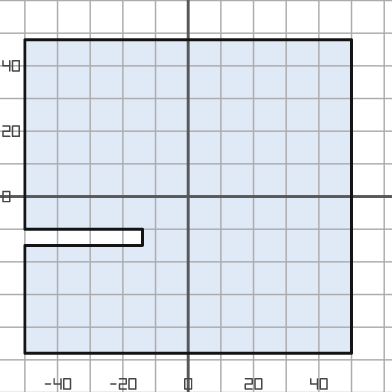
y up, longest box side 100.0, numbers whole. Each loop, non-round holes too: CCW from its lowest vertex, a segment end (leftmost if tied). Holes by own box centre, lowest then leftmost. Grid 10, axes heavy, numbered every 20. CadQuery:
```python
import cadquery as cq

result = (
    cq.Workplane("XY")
    .moveTo(-50.0, -48.0)
    .lineTo(50.0, -48.0)
    .lineTo(50.0, 48.0)
    .lineTo(-50.0, 48.0)
    .lineTo(-50.0, -10.0)
    .lineTo(-14.0, -10.0)
    .lineTo(-14.0, -15.0)
    .lineTo(-50.0, -15.0)
    .close()
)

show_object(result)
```